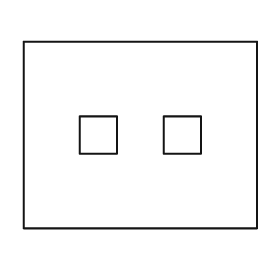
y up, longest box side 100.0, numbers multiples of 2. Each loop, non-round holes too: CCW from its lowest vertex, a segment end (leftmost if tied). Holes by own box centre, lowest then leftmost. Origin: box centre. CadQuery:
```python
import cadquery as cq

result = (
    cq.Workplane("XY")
    .moveTo(-50.0, -40.0)
    .lineTo(50.0, -40.0)
    .lineTo(50.0, 40.0)
    .lineTo(-50.0, 40.0)
    .close()
    .moveTo(-26.0, -8.0)
    .lineTo(-10.0, -8.0)
    .lineTo(-10.0, 8.0)
    .lineTo(-26.0, 8.0)
    .close()
    .moveTo(10.0, -8.0)
    .lineTo(26.0, -8.0)
    .lineTo(26.0, 8.0)
    .lineTo(10.0, 8.0)
    .close()
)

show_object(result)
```